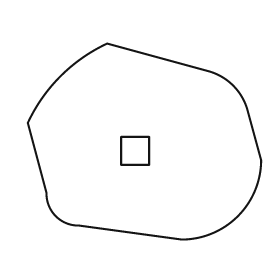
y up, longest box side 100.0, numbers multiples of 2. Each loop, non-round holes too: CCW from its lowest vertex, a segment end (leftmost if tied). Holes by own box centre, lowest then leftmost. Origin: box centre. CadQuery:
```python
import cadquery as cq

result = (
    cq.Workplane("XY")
    .moveTo(16.0, -42.0)
    .threePointArc((40.0, -32.0), (50.0, -8.0))
    .lineTo(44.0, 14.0)
    .threePointArc((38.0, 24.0), (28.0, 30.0))
    .lineTo(-16.0, 42.0)
    .threePointArc((-36.0, 28.0), (-50.0, 8.0))
    .lineTo(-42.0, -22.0)
    .threePointArc((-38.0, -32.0), (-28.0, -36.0))
    .close()
    .moveTo(-10.0, -10.0)
    .lineTo(2.0, -10.0)
    .lineTo(2.0, 2.0)
    .lineTo(-10.0, 2.0)
    .close()
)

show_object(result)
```